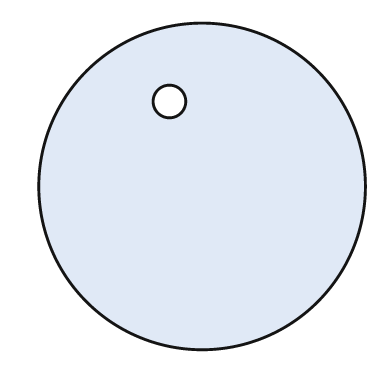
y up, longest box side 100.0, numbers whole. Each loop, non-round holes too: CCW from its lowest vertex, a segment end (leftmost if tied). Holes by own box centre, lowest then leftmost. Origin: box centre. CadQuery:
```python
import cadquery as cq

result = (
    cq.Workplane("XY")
    .moveTo(0.0, 0.0)
    .circle(50.0)
    .moveTo(-10.0, 26.0)
    .circle(5.0)
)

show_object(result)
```